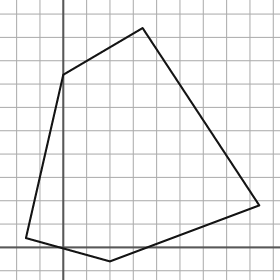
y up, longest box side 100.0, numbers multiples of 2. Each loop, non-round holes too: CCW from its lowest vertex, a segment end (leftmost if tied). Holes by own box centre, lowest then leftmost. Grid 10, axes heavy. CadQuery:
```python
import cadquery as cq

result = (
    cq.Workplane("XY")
    .moveTo(20.0, -6.0)
    .lineTo(84.0, 18.0)
    .lineTo(34.0, 94.0)
    .lineTo(0.0, 74.0)
    .lineTo(-16.0, 4.0)
    .close()
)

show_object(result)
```